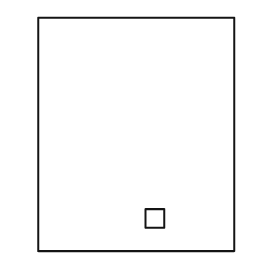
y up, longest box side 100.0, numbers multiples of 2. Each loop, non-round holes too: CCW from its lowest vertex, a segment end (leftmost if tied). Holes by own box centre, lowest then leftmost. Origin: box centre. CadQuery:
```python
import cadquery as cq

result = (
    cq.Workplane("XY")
    .moveTo(-42.0, -50.0)
    .lineTo(42.0, -50.0)
    .lineTo(42.0, 50.0)
    .lineTo(-42.0, 50.0)
    .close()
    .moveTo(4.0, -40.0)
    .lineTo(12.0, -40.0)
    .lineTo(12.0, -32.0)
    .lineTo(4.0, -32.0)
    .close()
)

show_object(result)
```